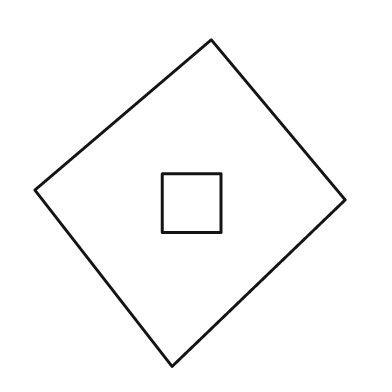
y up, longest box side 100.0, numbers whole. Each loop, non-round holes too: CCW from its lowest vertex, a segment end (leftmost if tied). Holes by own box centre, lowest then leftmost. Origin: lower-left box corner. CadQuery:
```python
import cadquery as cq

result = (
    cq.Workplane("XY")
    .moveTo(42.0, 0.0)
    .lineTo(95.0, 51.0)
    .lineTo(54.0, 100.0)
    .lineTo(0.0, 54.0)
    .close()
    .moveTo(39.0, 41.0)
    .lineTo(57.0, 41.0)
    .lineTo(57.0, 59.0)
    .lineTo(39.0, 59.0)
    .close()
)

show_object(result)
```